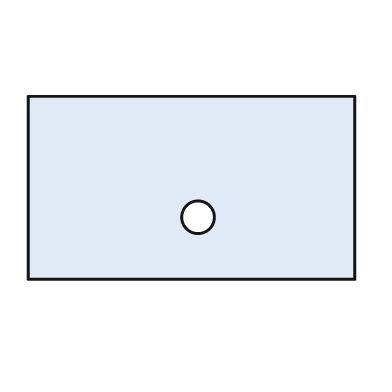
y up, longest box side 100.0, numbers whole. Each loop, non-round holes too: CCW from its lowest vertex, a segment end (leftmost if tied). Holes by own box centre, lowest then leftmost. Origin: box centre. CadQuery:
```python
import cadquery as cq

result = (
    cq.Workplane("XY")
    .moveTo(-50.0, -28.0)
    .lineTo(50.0, -28.0)
    .lineTo(50.0, 28.0)
    .lineTo(-50.0, 28.0)
    .close()
    .moveTo(2.0, -9.0)
    .circle(5.0)
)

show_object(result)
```